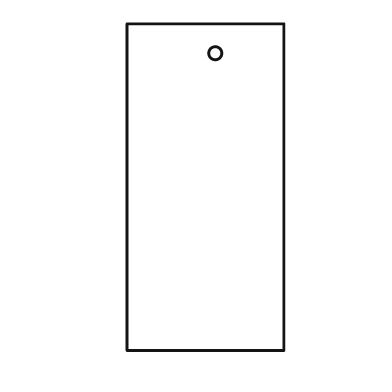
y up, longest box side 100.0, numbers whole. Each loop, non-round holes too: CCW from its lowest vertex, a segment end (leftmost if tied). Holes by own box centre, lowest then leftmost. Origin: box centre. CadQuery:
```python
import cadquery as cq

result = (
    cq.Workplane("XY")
    .moveTo(-24.0, -50.0)
    .lineTo(24.0, -50.0)
    .lineTo(24.0, 50.0)
    .lineTo(-24.0, 50.0)
    .close()
    .moveTo(3.0, 41.0)
    .circle(2.0)
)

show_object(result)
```